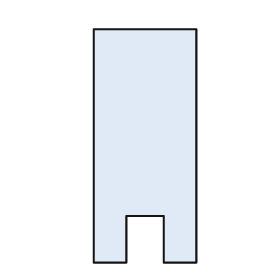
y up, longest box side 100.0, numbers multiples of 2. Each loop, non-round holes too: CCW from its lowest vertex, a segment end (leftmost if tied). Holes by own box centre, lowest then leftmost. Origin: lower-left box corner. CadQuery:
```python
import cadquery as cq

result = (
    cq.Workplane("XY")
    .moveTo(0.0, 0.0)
    .lineTo(14.0, 0.0)
    .lineTo(14.0, 20.0)
    .lineTo(30.0, 20.0)
    .lineTo(30.0, 0.0)
    .lineTo(44.0, 0.0)
    .lineTo(44.0, 100.0)
    .lineTo(0.0, 100.0)
    .close()
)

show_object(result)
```